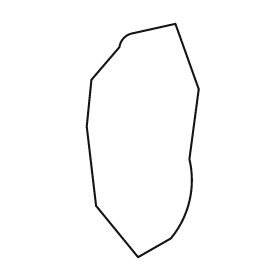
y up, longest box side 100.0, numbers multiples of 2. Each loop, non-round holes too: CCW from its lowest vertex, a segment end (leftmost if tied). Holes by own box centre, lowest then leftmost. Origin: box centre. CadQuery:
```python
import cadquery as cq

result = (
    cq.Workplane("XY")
    .moveTo(-2.0, -50.0)
    .lineTo(12.0, -42.0)
    .threePointArc((20.0, -26.0), (20.0, -8.0))
    .lineTo(24.0, 22.0)
    .lineTo(14.0, 50.0)
    .lineTo(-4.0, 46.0)
    .threePointArc((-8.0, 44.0), (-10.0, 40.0))
    .lineTo(-22.0, 26.0)
    .lineTo(-24.0, 6.0)
    .lineTo(-20.0, -28.0)
    .close()
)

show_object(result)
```